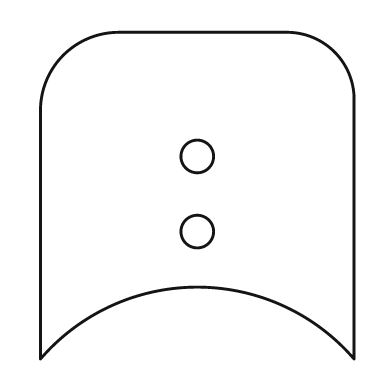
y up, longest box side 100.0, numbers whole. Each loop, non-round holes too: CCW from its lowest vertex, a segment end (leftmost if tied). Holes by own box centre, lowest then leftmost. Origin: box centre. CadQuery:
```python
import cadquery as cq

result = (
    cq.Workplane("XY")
    .moveTo(-48.0, -50.0)
    .threePointArc((0.0, -28.0), (48.0, -50.0))
    .lineTo(48.0, 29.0)
    .threePointArc((42.0, 44.0), (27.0, 50.0))
    .lineTo(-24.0, 50.0)
    .threePointArc((-41.0, 43.0), (-48.0, 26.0))
    .close()
    .moveTo(0.0, -11.0)
    .circle(5.0)
    .moveTo(0.0, 12.0)
    .circle(5.0)
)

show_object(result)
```